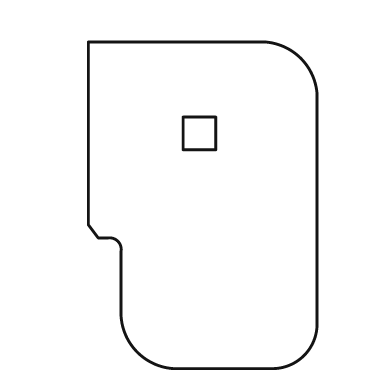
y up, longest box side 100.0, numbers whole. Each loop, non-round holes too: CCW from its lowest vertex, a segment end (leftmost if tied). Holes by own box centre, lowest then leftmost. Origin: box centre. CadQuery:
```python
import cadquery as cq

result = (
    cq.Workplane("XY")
    .moveTo(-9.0, -50.0)
    .lineTo(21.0, -50.0)
    .threePointArc((31.0, -46.0), (35.0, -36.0))
    .lineTo(35.0, 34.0)
    .threePointArc((30.0, 45.0), (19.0, 50.0))
    .lineTo(-35.0, 50.0)
    .lineTo(-35.0, -6.0)
    .lineTo(-32.0, -10.0)
    .lineTo(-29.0, -10.0)
    .threePointArc((-26.0, -11.0), (-25.0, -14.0))
    .lineTo(-25.0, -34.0)
    .threePointArc((-20.0, -45.0), (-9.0, -50.0))
    .close()
    .moveTo(-6.0, 17.0)
    .lineTo(4.0, 17.0)
    .lineTo(4.0, 27.0)
    .lineTo(-6.0, 27.0)
    .close()
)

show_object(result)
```